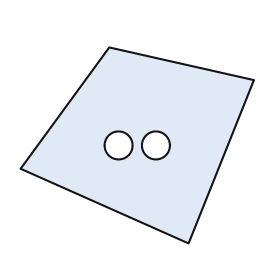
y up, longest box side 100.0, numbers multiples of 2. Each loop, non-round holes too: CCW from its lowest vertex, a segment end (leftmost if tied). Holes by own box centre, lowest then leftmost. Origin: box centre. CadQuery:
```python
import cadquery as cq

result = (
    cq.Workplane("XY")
    .moveTo(22.0, -42.0)
    .lineTo(50.0, 28.0)
    .lineTo(-12.0, 42.0)
    .lineTo(-50.0, -10.0)
    .close()
    .moveTo(-8.0, 0.0)
    .circle(6.0)
    .moveTo(8.0, 0.0)
    .circle(6.0)
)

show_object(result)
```